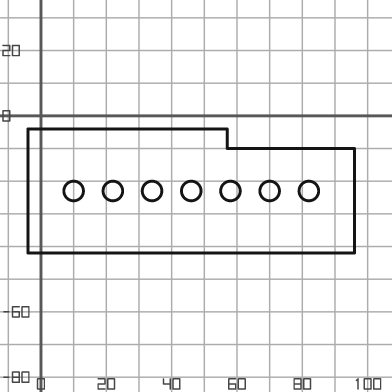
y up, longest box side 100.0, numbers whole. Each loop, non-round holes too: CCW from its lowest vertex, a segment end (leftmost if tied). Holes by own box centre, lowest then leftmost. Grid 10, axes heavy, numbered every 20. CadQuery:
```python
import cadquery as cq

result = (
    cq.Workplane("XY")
    .moveTo(-4.0, -42.0)
    .lineTo(96.0, -42.0)
    .lineTo(96.0, -10.0)
    .lineTo(57.0, -10.0)
    .lineTo(57.0, -4.0)
    .lineTo(-4.0, -4.0)
    .close()
    .moveTo(10.0, -23.0)
    .circle(3.0)
    .moveTo(22.0, -23.0)
    .circle(3.0)
    .moveTo(34.0, -23.0)
    .circle(3.0)
    .moveTo(46.0, -23.0)
    .circle(3.0)
    .moveTo(58.0, -23.0)
    .circle(3.0)
    .moveTo(70.0, -23.0)
    .circle(3.0)
    .moveTo(82.0, -23.0)
    .circle(3.0)
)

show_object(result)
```